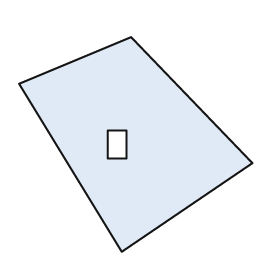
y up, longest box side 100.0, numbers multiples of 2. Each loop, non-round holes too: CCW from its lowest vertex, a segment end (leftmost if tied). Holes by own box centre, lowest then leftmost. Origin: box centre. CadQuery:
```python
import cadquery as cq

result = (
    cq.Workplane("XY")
    .moveTo(-6.0, -46.0)
    .lineTo(50.0, -8.0)
    .lineTo(-2.0, 46.0)
    .lineTo(-50.0, 26.0)
    .close()
    .moveTo(-12.0, -6.0)
    .lineTo(-4.0, -6.0)
    .lineTo(-4.0, 6.0)
    .lineTo(-12.0, 6.0)
    .close()
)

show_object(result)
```